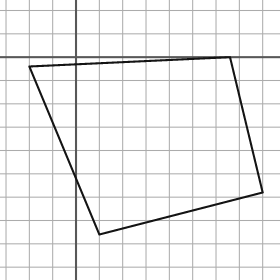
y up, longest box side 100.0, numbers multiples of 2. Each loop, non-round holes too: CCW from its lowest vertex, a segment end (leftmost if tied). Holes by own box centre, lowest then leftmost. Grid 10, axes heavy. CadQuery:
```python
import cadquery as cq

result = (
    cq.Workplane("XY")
    .moveTo(10.0, -76.0)
    .lineTo(80.0, -58.0)
    .lineTo(66.0, 0.0)
    .lineTo(-20.0, -4.0)
    .close()
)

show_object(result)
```